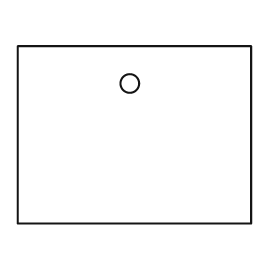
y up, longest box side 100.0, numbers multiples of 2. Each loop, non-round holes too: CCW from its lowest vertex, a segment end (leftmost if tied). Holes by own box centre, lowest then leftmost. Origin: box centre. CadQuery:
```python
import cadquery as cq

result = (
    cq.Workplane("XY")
    .moveTo(-50.0, -38.0)
    .lineTo(50.0, -38.0)
    .lineTo(50.0, 38.0)
    .lineTo(-50.0, 38.0)
    .close()
    .moveTo(-2.0, 22.0)
    .circle(4.0)
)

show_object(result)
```